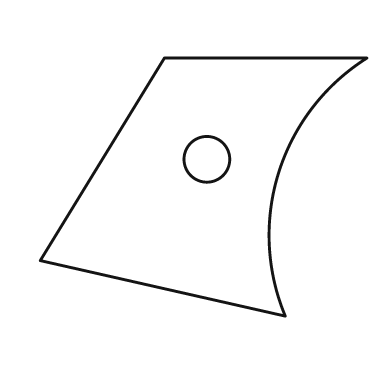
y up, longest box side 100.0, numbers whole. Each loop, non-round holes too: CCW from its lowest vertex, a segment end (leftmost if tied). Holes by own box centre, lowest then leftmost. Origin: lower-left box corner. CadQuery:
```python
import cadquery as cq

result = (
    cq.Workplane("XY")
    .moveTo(75.0, 0.0)
    .threePointArc((73.0, 44.0), (100.0, 79.0))
    .lineTo(38.0, 79.0)
    .lineTo(0.0, 17.0)
    .close()
    .moveTo(51.0, 48.0)
    .circle(7.0)
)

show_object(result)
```